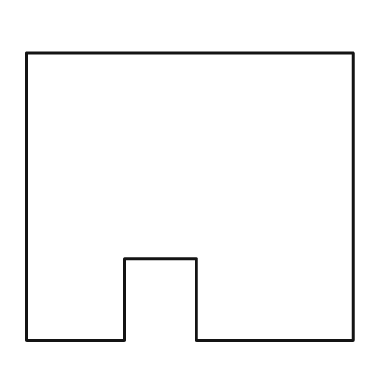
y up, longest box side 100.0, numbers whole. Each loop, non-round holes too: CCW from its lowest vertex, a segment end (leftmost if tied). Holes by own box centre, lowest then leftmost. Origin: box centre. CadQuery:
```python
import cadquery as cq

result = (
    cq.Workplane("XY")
    .moveTo(-50.0, -44.0)
    .lineTo(-20.0, -44.0)
    .lineTo(-20.0, -19.0)
    .lineTo(2.0, -19.0)
    .lineTo(2.0, -44.0)
    .lineTo(50.0, -44.0)
    .lineTo(50.0, 44.0)
    .lineTo(-50.0, 44.0)
    .close()
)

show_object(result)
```